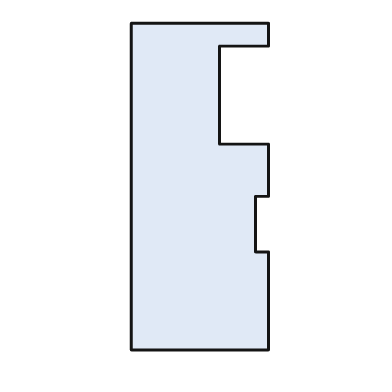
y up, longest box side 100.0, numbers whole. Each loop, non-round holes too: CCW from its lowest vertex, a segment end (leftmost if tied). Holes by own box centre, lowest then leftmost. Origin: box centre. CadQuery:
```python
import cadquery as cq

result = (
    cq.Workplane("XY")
    .moveTo(-21.0, -50.0)
    .lineTo(21.0, -50.0)
    .lineTo(21.0, -20.0)
    .lineTo(17.0, -20.0)
    .lineTo(17.0, -3.0)
    .lineTo(21.0, -3.0)
    .lineTo(21.0, 13.0)
    .lineTo(6.0, 13.0)
    .lineTo(6.0, 43.0)
    .lineTo(21.0, 43.0)
    .lineTo(21.0, 50.0)
    .lineTo(-21.0, 50.0)
    .close()
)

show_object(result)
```